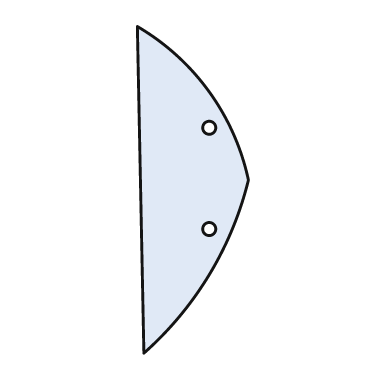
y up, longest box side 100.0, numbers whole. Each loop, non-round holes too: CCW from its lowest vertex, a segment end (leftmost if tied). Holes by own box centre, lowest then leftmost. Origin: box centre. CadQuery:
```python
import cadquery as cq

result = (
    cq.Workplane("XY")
    .moveTo(-15.0, -50.0)
    .threePointArc((5.0, -26.0), (17.0, 3.0))
    .threePointArc((5.0, 30.0), (-17.0, 50.0))
    .close()
    .moveTo(5.0, -12.0)
    .circle(2.0)
    .moveTo(5.0, 19.0)
    .circle(2.0)
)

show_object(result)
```